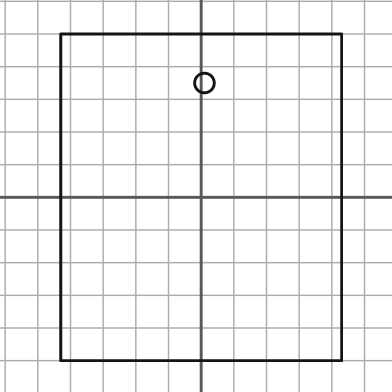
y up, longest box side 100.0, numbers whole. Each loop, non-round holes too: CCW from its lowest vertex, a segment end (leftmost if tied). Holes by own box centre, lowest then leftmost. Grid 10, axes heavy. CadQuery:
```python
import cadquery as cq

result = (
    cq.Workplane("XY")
    .moveTo(-43.0, -50.0)
    .lineTo(43.0, -50.0)
    .lineTo(43.0, 50.0)
    .lineTo(-43.0, 50.0)
    .close()
    .moveTo(1.0, 35.0)
    .circle(3.0)
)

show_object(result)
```